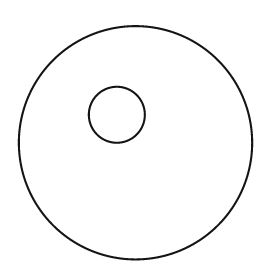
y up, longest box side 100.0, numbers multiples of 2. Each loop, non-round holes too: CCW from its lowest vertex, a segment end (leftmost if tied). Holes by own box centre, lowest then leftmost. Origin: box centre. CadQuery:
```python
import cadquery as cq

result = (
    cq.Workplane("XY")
    .moveTo(0.0, 0.0)
    .circle(50.0)
    .moveTo(-8.0, 12.0)
    .circle(12.0)
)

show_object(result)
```